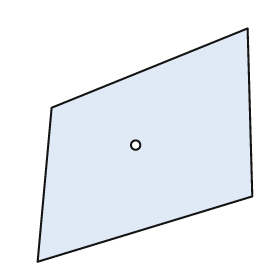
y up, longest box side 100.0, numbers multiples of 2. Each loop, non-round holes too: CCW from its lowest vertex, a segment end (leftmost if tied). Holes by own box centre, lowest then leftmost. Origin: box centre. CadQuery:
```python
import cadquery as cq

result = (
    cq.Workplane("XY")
    .moveTo(-46.0, -50.0)
    .lineTo(46.0, -22.0)
    .lineTo(44.0, 50.0)
    .lineTo(-40.0, 16.0)
    .close()
    .moveTo(-4.0, 0.0)
    .circle(2.0)
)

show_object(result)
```